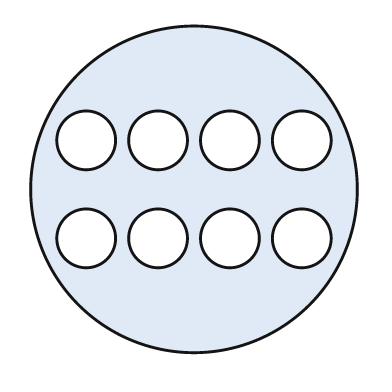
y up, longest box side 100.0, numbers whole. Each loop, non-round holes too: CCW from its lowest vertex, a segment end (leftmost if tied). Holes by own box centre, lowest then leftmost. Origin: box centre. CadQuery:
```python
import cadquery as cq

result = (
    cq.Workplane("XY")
    .moveTo(0.0, 0.0)
    .circle(50.0)
    .moveTo(-33.0, -15.0)
    .circle(9.0)
    .moveTo(-11.0, -15.0)
    .circle(9.0)
    .moveTo(11.0, -15.0)
    .circle(9.0)
    .moveTo(33.0, -15.0)
    .circle(9.0)
    .moveTo(-33.0, 15.0)
    .circle(9.0)
    .moveTo(-11.0, 15.0)
    .circle(9.0)
    .moveTo(11.0, 15.0)
    .circle(9.0)
    .moveTo(33.0, 15.0)
    .circle(9.0)
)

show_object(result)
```